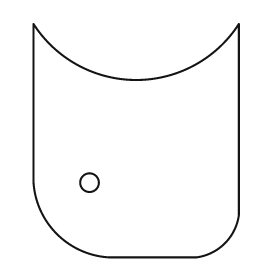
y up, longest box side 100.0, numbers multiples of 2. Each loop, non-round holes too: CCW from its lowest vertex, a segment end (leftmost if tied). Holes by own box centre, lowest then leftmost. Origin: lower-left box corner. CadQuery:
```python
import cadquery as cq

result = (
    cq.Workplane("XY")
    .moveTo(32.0, 0.0)
    .lineTo(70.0, 0.0)
    .threePointArc((82.0, 6.0), (88.0, 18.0))
    .lineTo(88.0, 100.0)
    .threePointArc((44.0, 76.0), (0.0, 100.0))
    .lineTo(0.0, 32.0)
    .threePointArc((10.0, 10.0), (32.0, 0.0))
    .close()
    .moveTo(24.0, 32.0)
    .circle(4.0)
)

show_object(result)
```